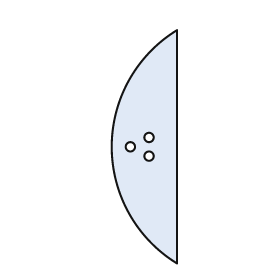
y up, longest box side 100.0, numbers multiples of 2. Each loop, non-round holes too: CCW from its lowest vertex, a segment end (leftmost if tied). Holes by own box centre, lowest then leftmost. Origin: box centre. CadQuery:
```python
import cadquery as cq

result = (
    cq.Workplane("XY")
    .moveTo(14.0, -50.0)
    .lineTo(14.0, 50.0)
    .threePointArc((-14.0, 0.0), (14.0, -50.0))
    .close()
    .moveTo(2.0, -4.0)
    .circle(2.0)
    .moveTo(-6.0, 0.0)
    .circle(2.0)
    .moveTo(2.0, 4.0)
    .circle(2.0)
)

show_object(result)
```